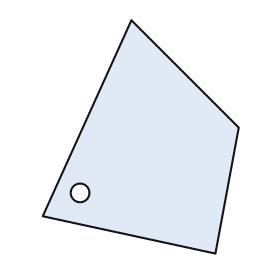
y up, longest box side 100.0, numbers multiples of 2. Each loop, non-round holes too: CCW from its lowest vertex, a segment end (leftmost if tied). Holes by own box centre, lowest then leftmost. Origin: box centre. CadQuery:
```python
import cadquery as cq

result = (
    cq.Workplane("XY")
    .moveTo(32.0, -50.0)
    .lineTo(42.0, 4.0)
    .lineTo(-4.0, 50.0)
    .lineTo(-42.0, -34.0)
    .close()
    .moveTo(-26.0, -24.0)
    .circle(4.0)
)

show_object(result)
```